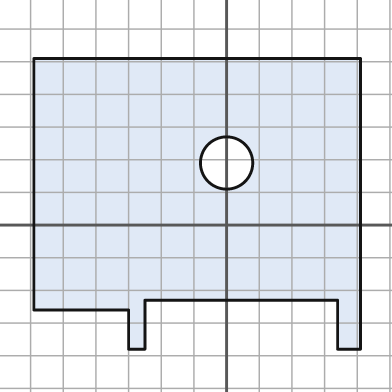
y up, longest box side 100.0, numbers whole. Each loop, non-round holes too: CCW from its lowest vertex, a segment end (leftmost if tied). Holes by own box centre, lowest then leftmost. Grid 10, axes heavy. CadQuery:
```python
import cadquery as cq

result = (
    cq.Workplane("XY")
    .moveTo(-30.0, -38.0)
    .lineTo(-25.0, -38.0)
    .lineTo(-25.0, -23.0)
    .lineTo(34.0, -23.0)
    .lineTo(34.0, -38.0)
    .lineTo(41.0, -38.0)
    .lineTo(41.0, 51.0)
    .lineTo(-59.0, 51.0)
    .lineTo(-59.0, -26.0)
    .lineTo(-30.0, -26.0)
    .close()
    .moveTo(0.0, 19.0)
    .circle(8.0)
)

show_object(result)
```